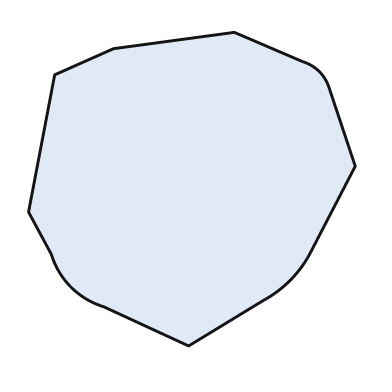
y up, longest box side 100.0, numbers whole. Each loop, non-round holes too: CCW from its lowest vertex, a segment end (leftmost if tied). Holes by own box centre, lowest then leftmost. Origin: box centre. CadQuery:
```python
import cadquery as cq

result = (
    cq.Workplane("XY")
    .moveTo(-1.0, -48.0)
    .lineTo(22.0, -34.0)
    .threePointArc((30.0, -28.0), (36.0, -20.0))
    .lineTo(50.0, 7.0)
    .lineTo(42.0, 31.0)
    .threePointArc((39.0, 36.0), (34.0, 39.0))
    .lineTo(13.0, 48.0)
    .lineTo(-24.0, 43.0)
    .lineTo(-42.0, 35.0)
    .lineTo(-50.0, -7.0)
    .lineTo(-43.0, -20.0)
    .threePointArc((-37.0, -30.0), (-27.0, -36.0))
    .close()
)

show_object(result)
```